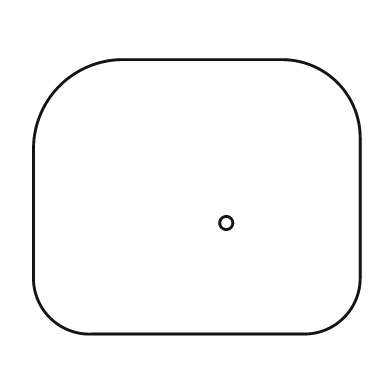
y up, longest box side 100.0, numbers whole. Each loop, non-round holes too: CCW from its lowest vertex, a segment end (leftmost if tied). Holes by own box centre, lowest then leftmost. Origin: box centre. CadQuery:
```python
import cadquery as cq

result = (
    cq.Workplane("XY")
    .moveTo(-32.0, -42.0)
    .lineTo(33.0, -42.0)
    .threePointArc((45.0, -37.0), (50.0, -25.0))
    .lineTo(50.0, 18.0)
    .threePointArc((43.0, 35.0), (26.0, 42.0))
    .lineTo(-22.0, 42.0)
    .threePointArc((-42.0, 34.0), (-50.0, 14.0))
    .lineTo(-50.0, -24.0)
    .threePointArc((-45.0, -37.0), (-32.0, -42.0))
    .close()
    .moveTo(9.0, -8.0)
    .circle(2.0)
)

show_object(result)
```